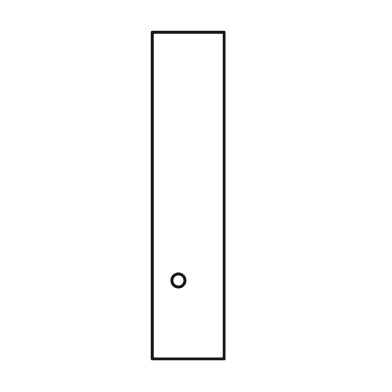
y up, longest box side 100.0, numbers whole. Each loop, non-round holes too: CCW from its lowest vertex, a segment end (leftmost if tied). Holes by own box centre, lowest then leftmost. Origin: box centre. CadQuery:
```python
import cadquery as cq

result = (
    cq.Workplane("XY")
    .moveTo(-11.0, -50.0)
    .lineTo(11.0, -50.0)
    .lineTo(11.0, 50.0)
    .lineTo(-11.0, 50.0)
    .close()
    .moveTo(-3.0, -26.0)
    .circle(2.0)
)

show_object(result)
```